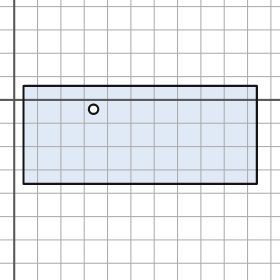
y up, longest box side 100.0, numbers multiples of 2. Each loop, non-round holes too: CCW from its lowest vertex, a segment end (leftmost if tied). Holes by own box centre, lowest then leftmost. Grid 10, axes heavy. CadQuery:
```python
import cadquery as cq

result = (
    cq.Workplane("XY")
    .moveTo(4.0, -36.0)
    .lineTo(104.0, -36.0)
    .lineTo(104.0, 6.0)
    .lineTo(4.0, 6.0)
    .close()
    .moveTo(34.0, -4.0)
    .circle(2.0)
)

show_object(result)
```